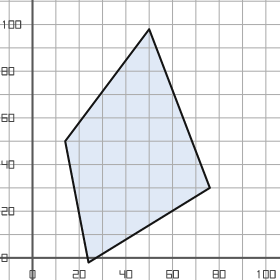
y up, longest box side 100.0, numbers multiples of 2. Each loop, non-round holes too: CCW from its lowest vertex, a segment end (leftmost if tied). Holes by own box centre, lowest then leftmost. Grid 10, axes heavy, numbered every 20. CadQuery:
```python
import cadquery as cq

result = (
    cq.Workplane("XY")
    .moveTo(24.0, -2.0)
    .lineTo(76.0, 30.0)
    .lineTo(50.0, 98.0)
    .lineTo(14.0, 50.0)
    .close()
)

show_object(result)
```